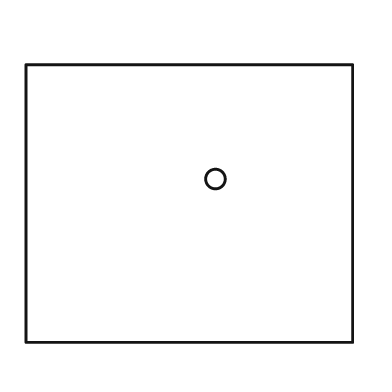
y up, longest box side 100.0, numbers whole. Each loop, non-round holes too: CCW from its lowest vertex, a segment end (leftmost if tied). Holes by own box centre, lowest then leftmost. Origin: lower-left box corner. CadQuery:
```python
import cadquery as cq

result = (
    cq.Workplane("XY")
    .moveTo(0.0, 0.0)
    .lineTo(100.0, 0.0)
    .lineTo(100.0, 85.0)
    .lineTo(0.0, 85.0)
    .close()
    .moveTo(58.0, 50.0)
    .circle(3.0)
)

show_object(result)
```